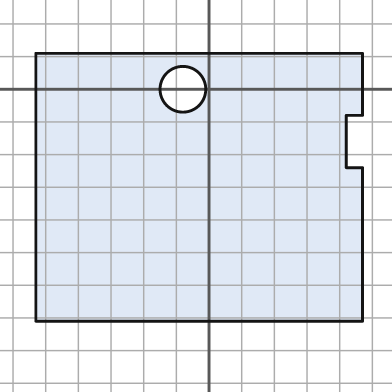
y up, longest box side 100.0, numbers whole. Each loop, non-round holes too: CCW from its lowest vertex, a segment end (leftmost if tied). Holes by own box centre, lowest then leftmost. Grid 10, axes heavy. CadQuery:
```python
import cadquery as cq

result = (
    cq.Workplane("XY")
    .moveTo(-53.0, -71.0)
    .lineTo(47.0, -71.0)
    .lineTo(47.0, -24.0)
    .lineTo(42.0, -24.0)
    .lineTo(42.0, -8.0)
    .lineTo(47.0, -8.0)
    .lineTo(47.0, 11.0)
    .lineTo(-53.0, 11.0)
    .close()
    .moveTo(-8.0, 0.0)
    .circle(7.0)
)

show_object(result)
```